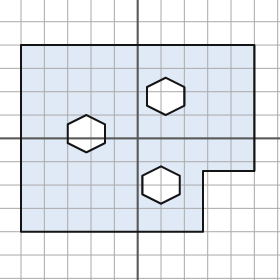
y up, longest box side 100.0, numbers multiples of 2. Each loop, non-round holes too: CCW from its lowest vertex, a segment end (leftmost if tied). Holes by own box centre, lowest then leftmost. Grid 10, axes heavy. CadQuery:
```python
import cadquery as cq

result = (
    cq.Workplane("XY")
    .moveTo(-50.0, -40.0)
    .lineTo(28.0, -40.0)
    .lineTo(28.0, -14.0)
    .lineTo(50.0, -14.0)
    .lineTo(50.0, 40.0)
    .lineTo(-50.0, 40.0)
    .close()
    .moveTo(10.0, -28.0)
    .lineTo(18.0, -24.0)
    .lineTo(18.0, -16.0)
    .lineTo(10.0, -12.0)
    .lineTo(2.0, -16.0)
    .lineTo(2.0, -24.0)
    .close()
    .moveTo(-22.0, -6.0)
    .lineTo(-14.0, -2.0)
    .lineTo(-14.0, 6.0)
    .lineTo(-22.0, 10.0)
    .lineTo(-30.0, 6.0)
    .lineTo(-30.0, -2.0)
    .close()
    .moveTo(12.0, 10.0)
    .lineTo(20.0, 14.0)
    .lineTo(20.0, 22.0)
    .lineTo(12.0, 26.0)
    .lineTo(4.0, 22.0)
    .lineTo(4.0, 14.0)
    .close()
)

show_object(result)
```